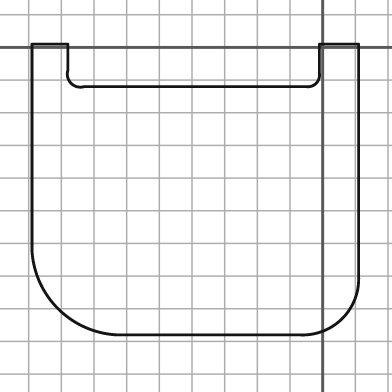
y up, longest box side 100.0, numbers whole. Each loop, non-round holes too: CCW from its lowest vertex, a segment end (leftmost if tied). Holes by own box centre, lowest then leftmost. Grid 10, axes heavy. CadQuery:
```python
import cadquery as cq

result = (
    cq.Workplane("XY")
    .moveTo(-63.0, -88.0)
    .lineTo(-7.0, -88.0)
    .threePointArc((6.0, -83.0), (11.0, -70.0))
    .lineTo(11.0, 1.0)
    .lineTo(-1.0, 1.0)
    .lineTo(-1.0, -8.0)
    .threePointArc((-2.0, -11.0), (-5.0, -12.0))
    .lineTo(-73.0, -12.0)
    .threePointArc((-77.0, -11.0), (-78.0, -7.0))
    .lineTo(-78.0, 1.0)
    .lineTo(-89.0, 1.0)
    .lineTo(-89.0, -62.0)
    .threePointArc((-81.0, -80.0), (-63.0, -88.0))
    .close()
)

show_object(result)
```